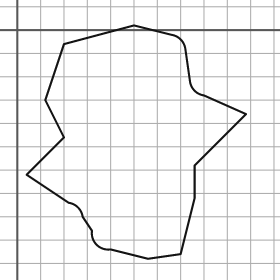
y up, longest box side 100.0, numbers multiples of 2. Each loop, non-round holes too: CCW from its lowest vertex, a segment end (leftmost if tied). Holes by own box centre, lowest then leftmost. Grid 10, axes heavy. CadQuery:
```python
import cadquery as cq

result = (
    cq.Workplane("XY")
    .moveTo(56.0, -98.0)
    .lineTo(70.0, -96.0)
    .lineTo(76.0, -72.0)
    .lineTo(76.0, -58.0)
    .lineTo(98.0, -36.0)
    .lineTo(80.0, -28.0)
    .threePointArc((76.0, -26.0), (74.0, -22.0))
    .lineTo(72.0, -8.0)
    .threePointArc((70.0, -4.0), (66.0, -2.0))
    .lineTo(50.0, 2.0)
    .lineTo(20.0, -6.0)
    .lineTo(12.0, -30.0)
    .lineTo(20.0, -46.0)
    .lineTo(4.0, -62.0)
    .lineTo(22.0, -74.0)
    .threePointArc((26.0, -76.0), (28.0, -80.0))
    .lineTo(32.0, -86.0)
    .threePointArc((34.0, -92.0), (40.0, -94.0))
    .close()
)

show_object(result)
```